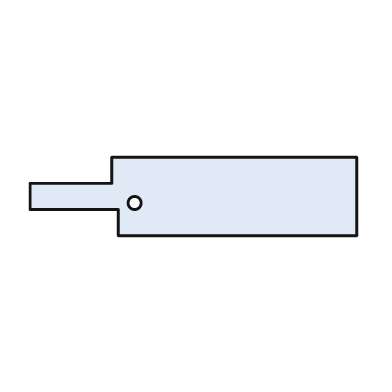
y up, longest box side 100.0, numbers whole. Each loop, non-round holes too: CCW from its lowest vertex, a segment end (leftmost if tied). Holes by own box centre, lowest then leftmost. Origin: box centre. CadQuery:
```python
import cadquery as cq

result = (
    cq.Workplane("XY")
    .moveTo(-23.0, -12.0)
    .lineTo(50.0, -12.0)
    .lineTo(50.0, 12.0)
    .lineTo(-25.0, 12.0)
    .lineTo(-25.0, 4.0)
    .lineTo(-50.0, 4.0)
    .lineTo(-50.0, -4.0)
    .lineTo(-23.0, -4.0)
    .close()
    .moveTo(-18.0, -2.0)
    .circle(2.0)
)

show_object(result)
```